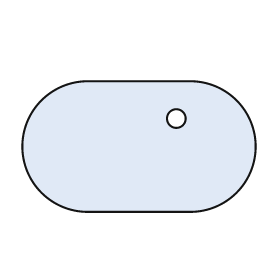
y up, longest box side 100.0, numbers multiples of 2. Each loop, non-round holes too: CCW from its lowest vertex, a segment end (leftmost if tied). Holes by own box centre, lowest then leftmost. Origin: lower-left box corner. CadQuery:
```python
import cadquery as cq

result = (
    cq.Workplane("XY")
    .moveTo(28.0, 0.0)
    .lineTo(72.0, 0.0)
    .threePointArc((100.0, 28.0), (72.0, 56.0))
    .lineTo(28.0, 56.0)
    .threePointArc((0.0, 28.0), (28.0, 0.0))
    .close()
    .moveTo(66.0, 40.0)
    .circle(4.0)
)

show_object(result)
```